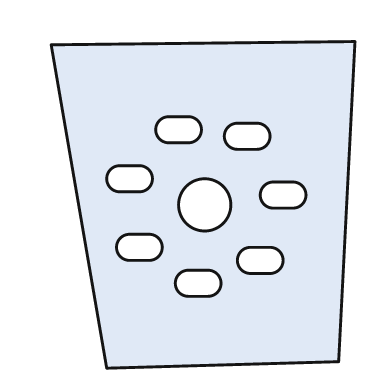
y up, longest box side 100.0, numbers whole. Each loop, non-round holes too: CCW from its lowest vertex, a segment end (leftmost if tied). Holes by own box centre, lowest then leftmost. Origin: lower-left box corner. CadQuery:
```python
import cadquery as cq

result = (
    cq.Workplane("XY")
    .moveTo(17.0, 0.0)
    .lineTo(88.0, 2.0)
    .lineTo(93.0, 100.0)
    .lineTo(0.0, 99.0)
    .close()
    .moveTo(42.0, 22.0)
    .lineTo(48.0, 22.0)
    .threePointArc((52.0, 26.0), (48.0, 30.0))
    .lineTo(42.0, 30.0)
    .threePointArc((38.0, 26.0), (42.0, 22.0))
    .close()
    .moveTo(61.0, 29.0)
    .lineTo(67.0, 29.0)
    .threePointArc((71.0, 33.0), (67.0, 37.0))
    .lineTo(61.0, 37.0)
    .threePointArc((57.0, 33.0), (61.0, 29.0))
    .close()
    .moveTo(24.0, 33.0)
    .lineTo(30.0, 33.0)
    .threePointArc((34.0, 37.0), (30.0, 41.0))
    .lineTo(24.0, 41.0)
    .threePointArc((20.0, 37.0), (24.0, 33.0))
    .close()
    .moveTo(47.0, 50.0)
    .circle(8.0)
    .moveTo(68.0, 49.0)
    .lineTo(74.0, 49.0)
    .threePointArc((78.0, 53.0), (74.0, 57.0))
    .lineTo(68.0, 57.0)
    .threePointArc((64.0, 53.0), (68.0, 49.0))
    .close()
    .moveTo(21.0, 54.0)
    .lineTo(27.0, 54.0)
    .threePointArc((31.0, 58.0), (27.0, 62.0))
    .lineTo(21.0, 62.0)
    .threePointArc((17.0, 58.0), (21.0, 54.0))
    .close()
    .moveTo(57.0, 67.0)
    .lineTo(63.0, 67.0)
    .threePointArc((67.0, 71.0), (63.0, 75.0))
    .lineTo(57.0, 75.0)
    .threePointArc((53.0, 71.0), (57.0, 67.0))
    .close()
    .moveTo(36.0, 69.0)
    .lineTo(42.0, 69.0)
    .threePointArc((46.0, 73.0), (42.0, 77.0))
    .lineTo(36.0, 77.0)
    .threePointArc((32.0, 73.0), (36.0, 69.0))
    .close()
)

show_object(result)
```